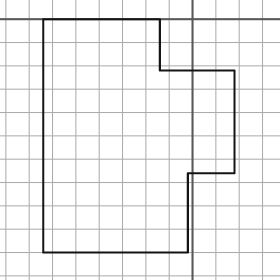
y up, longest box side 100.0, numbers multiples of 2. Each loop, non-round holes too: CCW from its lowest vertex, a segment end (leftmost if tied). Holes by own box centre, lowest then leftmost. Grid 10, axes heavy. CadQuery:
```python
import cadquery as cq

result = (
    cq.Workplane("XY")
    .moveTo(-64.0, -100.0)
    .lineTo(-2.0, -100.0)
    .lineTo(-2.0, -66.0)
    .lineTo(18.0, -66.0)
    .lineTo(18.0, -22.0)
    .lineTo(-14.0, -22.0)
    .lineTo(-14.0, 0.0)
    .lineTo(-64.0, 0.0)
    .close()
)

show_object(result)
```